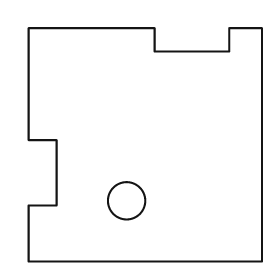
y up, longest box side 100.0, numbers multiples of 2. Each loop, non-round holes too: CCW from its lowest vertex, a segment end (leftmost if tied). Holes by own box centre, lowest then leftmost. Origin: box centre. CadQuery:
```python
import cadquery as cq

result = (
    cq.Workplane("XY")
    .moveTo(-50.0, -50.0)
    .lineTo(50.0, -50.0)
    .lineTo(50.0, 50.0)
    .lineTo(36.0, 50.0)
    .lineTo(36.0, 40.0)
    .lineTo(4.0, 40.0)
    .lineTo(4.0, 50.0)
    .lineTo(-50.0, 50.0)
    .lineTo(-50.0, 2.0)
    .lineTo(-38.0, 2.0)
    .lineTo(-38.0, -26.0)
    .lineTo(-50.0, -26.0)
    .close()
    .moveTo(-8.0, -24.0)
    .circle(8.0)
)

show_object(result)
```